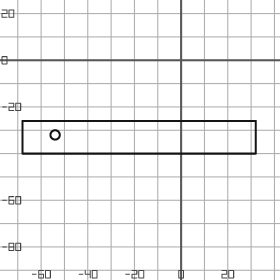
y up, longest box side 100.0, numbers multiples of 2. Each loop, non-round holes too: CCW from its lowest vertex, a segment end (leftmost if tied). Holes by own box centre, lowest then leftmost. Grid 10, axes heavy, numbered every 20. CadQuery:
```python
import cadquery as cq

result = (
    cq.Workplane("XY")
    .moveTo(-68.0, -40.0)
    .lineTo(32.0, -40.0)
    .lineTo(32.0, -26.0)
    .lineTo(-68.0, -26.0)
    .close()
    .moveTo(-54.0, -32.0)
    .circle(2.0)
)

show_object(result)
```